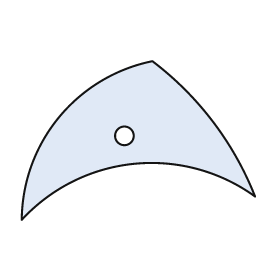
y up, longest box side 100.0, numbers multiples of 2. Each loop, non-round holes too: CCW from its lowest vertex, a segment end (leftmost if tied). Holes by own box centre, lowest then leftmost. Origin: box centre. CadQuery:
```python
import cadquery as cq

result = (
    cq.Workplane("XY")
    .moveTo(-50.0, -34.0)
    .threePointArc((-2.0, -10.0), (50.0, -24.0))
    .threePointArc((32.0, 8.0), (6.0, 34.0))
    .threePointArc((-34.0, 10.0), (-50.0, -34.0))
    .close()
    .moveTo(-6.0, 2.0)
    .circle(4.0)
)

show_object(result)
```